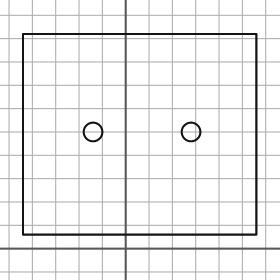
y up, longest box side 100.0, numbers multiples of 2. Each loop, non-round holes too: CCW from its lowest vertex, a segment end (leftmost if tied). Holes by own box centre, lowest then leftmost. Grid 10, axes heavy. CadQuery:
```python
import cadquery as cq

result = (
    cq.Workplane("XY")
    .moveTo(-44.0, 6.0)
    .lineTo(56.0, 6.0)
    .lineTo(56.0, 92.0)
    .lineTo(-44.0, 92.0)
    .close()
    .moveTo(-14.0, 50.0)
    .circle(4.0)
    .moveTo(28.0, 50.0)
    .circle(4.0)
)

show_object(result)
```